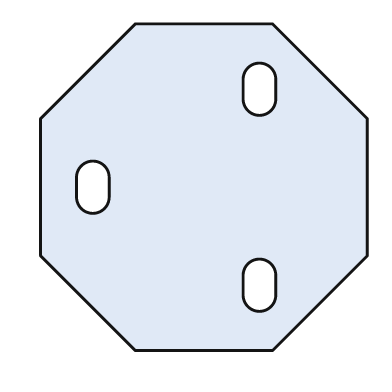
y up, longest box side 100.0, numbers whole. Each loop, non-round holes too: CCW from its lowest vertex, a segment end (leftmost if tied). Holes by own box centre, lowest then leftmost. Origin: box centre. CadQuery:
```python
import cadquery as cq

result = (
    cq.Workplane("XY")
    .moveTo(-21.0, -50.0)
    .lineTo(21.0, -50.0)
    .lineTo(50.0, -21.0)
    .lineTo(50.0, 21.0)
    .lineTo(21.0, 50.0)
    .lineTo(-21.0, 50.0)
    .lineTo(-50.0, 21.0)
    .lineTo(-50.0, -21.0)
    .close()
    .moveTo(12.0, -33.0)
    .threePointArc((17.0, -38.0), (22.0, -33.0))
    .lineTo(22.0, -27.0)
    .threePointArc((17.0, -22.0), (12.0, -27.0))
    .close()
    .moveTo(-39.0, -3.0)
    .threePointArc((-34.0, -8.0), (-29.0, -3.0))
    .lineTo(-29.0, 3.0)
    .threePointArc((-34.0, 8.0), (-39.0, 3.0))
    .close()
    .moveTo(12.0, 27.0)
    .threePointArc((17.0, 22.0), (22.0, 27.0))
    .lineTo(22.0, 33.0)
    .threePointArc((17.0, 38.0), (12.0, 33.0))
    .close()
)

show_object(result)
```